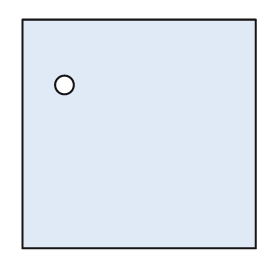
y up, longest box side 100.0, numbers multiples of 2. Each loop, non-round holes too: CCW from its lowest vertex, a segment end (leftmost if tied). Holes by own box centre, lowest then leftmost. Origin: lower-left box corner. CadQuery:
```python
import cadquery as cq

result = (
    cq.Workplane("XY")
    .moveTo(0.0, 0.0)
    .lineTo(100.0, 0.0)
    .lineTo(100.0, 98.0)
    .lineTo(0.0, 98.0)
    .close()
    .moveTo(18.0, 70.0)
    .circle(4.0)
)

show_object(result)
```